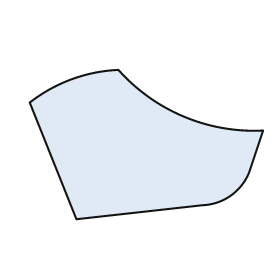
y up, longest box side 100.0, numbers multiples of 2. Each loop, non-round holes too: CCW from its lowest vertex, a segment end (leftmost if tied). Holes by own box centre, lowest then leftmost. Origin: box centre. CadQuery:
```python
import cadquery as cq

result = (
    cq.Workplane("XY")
    .moveTo(-30.0, -32.0)
    .lineTo(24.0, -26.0)
    .threePointArc((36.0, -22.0), (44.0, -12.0))
    .lineTo(50.0, 6.0)
    .threePointArc((16.0, 12.0), (-12.0, 32.0))
    .threePointArc((-32.0, 28.0), (-50.0, 18.0))
    .close()
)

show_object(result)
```